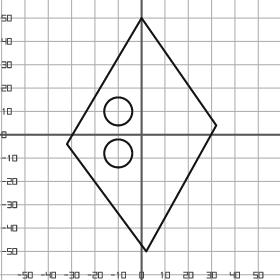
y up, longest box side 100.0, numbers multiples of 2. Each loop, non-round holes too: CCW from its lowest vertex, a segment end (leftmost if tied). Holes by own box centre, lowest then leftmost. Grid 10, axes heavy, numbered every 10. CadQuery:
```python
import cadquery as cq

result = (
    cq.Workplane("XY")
    .moveTo(2.0, -50.0)
    .lineTo(32.0, 4.0)
    .lineTo(0.0, 50.0)
    .lineTo(-32.0, -4.0)
    .close()
    .moveTo(-10.0, -8.0)
    .circle(6.0)
    .moveTo(-10.0, 10.0)
    .circle(6.0)
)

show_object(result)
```